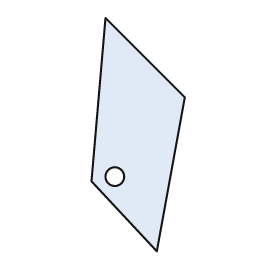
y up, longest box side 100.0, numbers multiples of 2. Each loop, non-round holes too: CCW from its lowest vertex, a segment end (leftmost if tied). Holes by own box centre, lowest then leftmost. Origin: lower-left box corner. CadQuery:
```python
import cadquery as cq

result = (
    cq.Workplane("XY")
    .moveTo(28.0, 0.0)
    .lineTo(40.0, 66.0)
    .lineTo(6.0, 100.0)
    .lineTo(0.0, 30.0)
    .close()
    .moveTo(10.0, 32.0)
    .circle(4.0)
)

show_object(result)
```